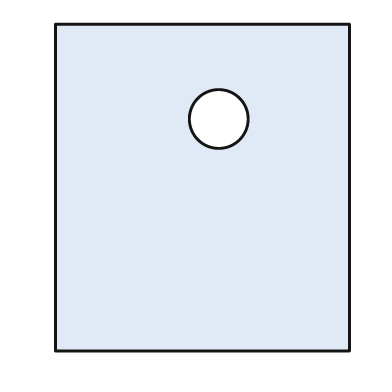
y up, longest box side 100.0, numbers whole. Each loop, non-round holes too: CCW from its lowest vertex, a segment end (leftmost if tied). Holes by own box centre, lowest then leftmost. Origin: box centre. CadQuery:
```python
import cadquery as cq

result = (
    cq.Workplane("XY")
    .moveTo(-45.0, -50.0)
    .lineTo(45.0, -50.0)
    .lineTo(45.0, 50.0)
    .lineTo(-45.0, 50.0)
    .close()
    .moveTo(5.0, 21.0)
    .circle(9.0)
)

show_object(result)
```